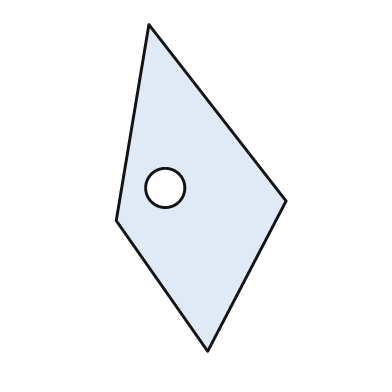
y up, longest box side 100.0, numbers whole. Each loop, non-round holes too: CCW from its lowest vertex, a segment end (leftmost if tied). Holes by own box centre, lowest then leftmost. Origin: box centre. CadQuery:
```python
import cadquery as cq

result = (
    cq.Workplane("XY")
    .moveTo(2.0, -50.0)
    .lineTo(26.0, -4.0)
    .lineTo(-16.0, 50.0)
    .lineTo(-26.0, -10.0)
    .close()
    .moveTo(-11.0, 0.0)
    .circle(6.0)
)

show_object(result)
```